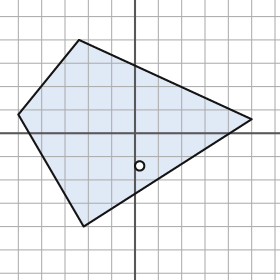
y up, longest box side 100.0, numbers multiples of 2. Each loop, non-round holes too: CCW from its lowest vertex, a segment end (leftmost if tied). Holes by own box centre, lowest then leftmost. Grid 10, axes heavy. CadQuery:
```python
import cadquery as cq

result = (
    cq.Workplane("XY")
    .moveTo(-22.0, -40.0)
    .lineTo(50.0, 6.0)
    .lineTo(-24.0, 40.0)
    .lineTo(-50.0, 8.0)
    .close()
    .moveTo(2.0, -14.0)
    .circle(2.0)
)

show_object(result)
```